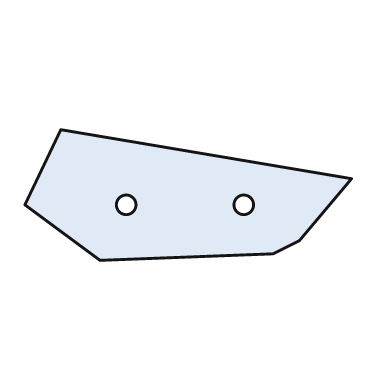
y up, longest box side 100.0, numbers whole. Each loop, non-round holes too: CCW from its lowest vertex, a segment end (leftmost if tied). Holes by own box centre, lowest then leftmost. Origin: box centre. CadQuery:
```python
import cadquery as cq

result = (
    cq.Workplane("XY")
    .moveTo(-27.0, -20.0)
    .lineTo(26.0, -18.0)
    .lineTo(34.0, -14.0)
    .lineTo(50.0, 5.0)
    .lineTo(-39.0, 20.0)
    .lineTo(-50.0, -3.0)
    .close()
    .moveTo(-19.0, -3.0)
    .circle(3.0)
    .moveTo(17.0, -3.0)
    .circle(3.0)
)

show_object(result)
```